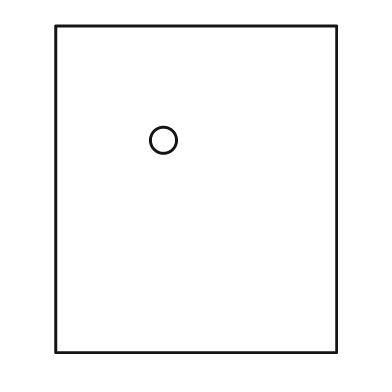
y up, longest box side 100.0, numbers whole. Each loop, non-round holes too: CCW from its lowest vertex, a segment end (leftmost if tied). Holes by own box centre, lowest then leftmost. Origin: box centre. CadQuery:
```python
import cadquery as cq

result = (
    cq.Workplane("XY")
    .moveTo(-43.0, -50.0)
    .lineTo(43.0, -50.0)
    .lineTo(43.0, 50.0)
    .lineTo(-43.0, 50.0)
    .close()
    .moveTo(-10.0, 15.0)
    .circle(4.0)
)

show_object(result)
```